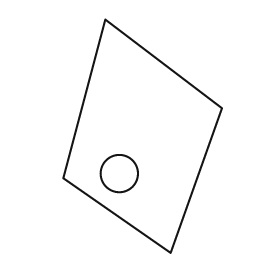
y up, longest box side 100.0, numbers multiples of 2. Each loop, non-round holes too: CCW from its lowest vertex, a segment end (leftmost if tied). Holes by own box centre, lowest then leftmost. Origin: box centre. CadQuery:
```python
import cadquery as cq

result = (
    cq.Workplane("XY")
    .moveTo(12.0, -50.0)
    .lineTo(34.0, 12.0)
    .lineTo(-16.0, 50.0)
    .lineTo(-34.0, -18.0)
    .close()
    .moveTo(-10.0, -16.0)
    .circle(8.0)
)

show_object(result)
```